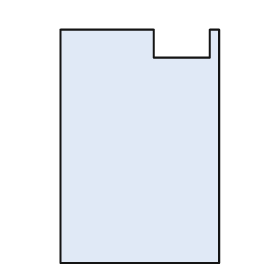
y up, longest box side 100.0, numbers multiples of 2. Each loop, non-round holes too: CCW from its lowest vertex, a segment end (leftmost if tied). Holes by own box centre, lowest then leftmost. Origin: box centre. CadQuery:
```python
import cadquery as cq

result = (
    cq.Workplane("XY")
    .moveTo(-34.0, -50.0)
    .lineTo(34.0, -50.0)
    .lineTo(34.0, 50.0)
    .lineTo(30.0, 50.0)
    .lineTo(30.0, 38.0)
    .lineTo(6.0, 38.0)
    .lineTo(6.0, 50.0)
    .lineTo(-34.0, 50.0)
    .close()
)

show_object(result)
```